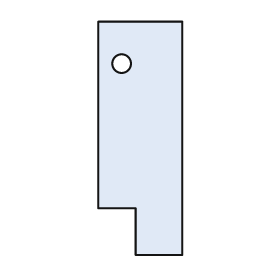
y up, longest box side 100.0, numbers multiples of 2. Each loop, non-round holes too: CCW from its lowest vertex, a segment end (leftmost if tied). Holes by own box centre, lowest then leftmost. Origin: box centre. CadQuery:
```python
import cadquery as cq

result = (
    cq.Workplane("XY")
    .moveTo(-2.0, -50.0)
    .lineTo(18.0, -50.0)
    .lineTo(18.0, 50.0)
    .lineTo(-18.0, 50.0)
    .lineTo(-18.0, -30.0)
    .lineTo(-2.0, -30.0)
    .close()
    .moveTo(-8.0, 32.0)
    .circle(4.0)
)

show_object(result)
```